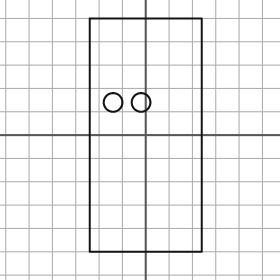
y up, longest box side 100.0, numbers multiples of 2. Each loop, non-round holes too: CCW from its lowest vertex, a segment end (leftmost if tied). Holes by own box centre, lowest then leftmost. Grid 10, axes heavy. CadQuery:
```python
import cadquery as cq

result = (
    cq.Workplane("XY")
    .moveTo(-24.0, -50.0)
    .lineTo(24.0, -50.0)
    .lineTo(24.0, 50.0)
    .lineTo(-24.0, 50.0)
    .close()
    .moveTo(-14.0, 14.0)
    .circle(4.0)
    .moveTo(-2.0, 14.0)
    .circle(4.0)
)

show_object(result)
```